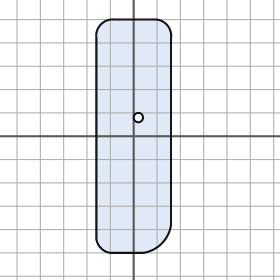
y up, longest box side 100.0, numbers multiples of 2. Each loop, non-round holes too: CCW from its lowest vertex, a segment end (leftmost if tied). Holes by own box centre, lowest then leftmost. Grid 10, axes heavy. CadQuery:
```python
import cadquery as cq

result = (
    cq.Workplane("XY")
    .moveTo(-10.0, -50.0)
    .lineTo(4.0, -50.0)
    .threePointArc((12.0, -46.0), (16.0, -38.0))
    .lineTo(16.0, 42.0)
    .threePointArc((14.0, 48.0), (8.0, 50.0))
    .lineTo(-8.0, 50.0)
    .threePointArc((-14.0, 48.0), (-16.0, 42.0))
    .lineTo(-16.0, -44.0)
    .threePointArc((-14.0, -48.0), (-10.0, -50.0))
    .close()
    .moveTo(2.0, 8.0)
    .circle(2.0)
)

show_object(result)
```